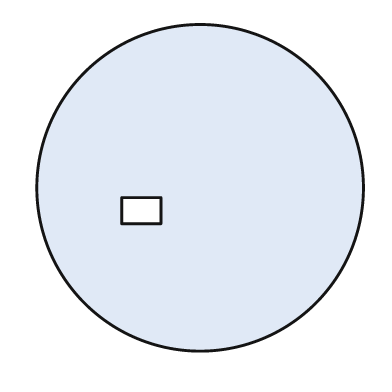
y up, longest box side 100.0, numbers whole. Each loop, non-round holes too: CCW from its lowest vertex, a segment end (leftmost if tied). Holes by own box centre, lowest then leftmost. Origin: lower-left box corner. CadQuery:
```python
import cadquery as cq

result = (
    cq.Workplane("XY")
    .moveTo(50.0, 50.0)
    .circle(50.0)
    .moveTo(26.0, 39.0)
    .lineTo(38.0, 39.0)
    .lineTo(38.0, 47.0)
    .lineTo(26.0, 47.0)
    .close()
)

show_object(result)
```